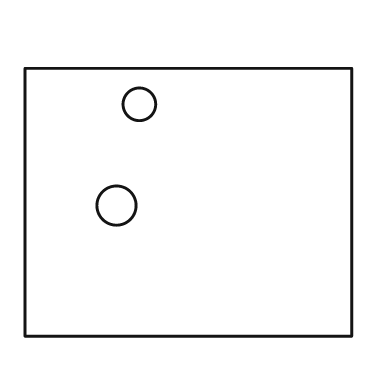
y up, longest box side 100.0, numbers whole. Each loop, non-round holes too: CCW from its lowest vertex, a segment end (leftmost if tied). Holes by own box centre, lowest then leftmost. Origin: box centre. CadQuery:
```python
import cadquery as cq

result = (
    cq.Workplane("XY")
    .moveTo(-50.0, -41.0)
    .lineTo(50.0, -41.0)
    .lineTo(50.0, 41.0)
    .lineTo(-50.0, 41.0)
    .close()
    .moveTo(-22.0, -1.0)
    .circle(6.0)
    .moveTo(-15.0, 30.0)
    .circle(5.0)
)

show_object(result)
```